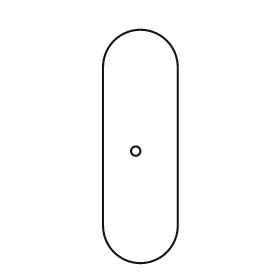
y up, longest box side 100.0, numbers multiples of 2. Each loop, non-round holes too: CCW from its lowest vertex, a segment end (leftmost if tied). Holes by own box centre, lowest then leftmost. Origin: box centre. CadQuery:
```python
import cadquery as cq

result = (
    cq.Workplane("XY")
    .moveTo(-16.0, -34.0)
    .threePointArc((0.0, -50.0), (16.0, -34.0))
    .lineTo(16.0, 34.0)
    .threePointArc((0.0, 50.0), (-16.0, 34.0))
    .close()
    .moveTo(-2.0, -2.0)
    .circle(2.0)
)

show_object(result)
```